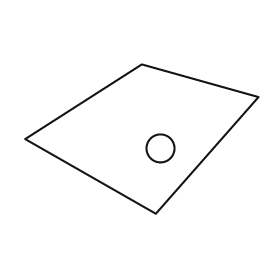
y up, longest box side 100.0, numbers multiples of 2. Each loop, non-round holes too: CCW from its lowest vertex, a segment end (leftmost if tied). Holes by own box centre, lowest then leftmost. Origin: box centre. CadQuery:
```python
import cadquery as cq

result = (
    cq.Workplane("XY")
    .moveTo(6.0, -32.0)
    .lineTo(50.0, 18.0)
    .lineTo(0.0, 32.0)
    .lineTo(-50.0, 0.0)
    .close()
    .moveTo(8.0, -4.0)
    .circle(6.0)
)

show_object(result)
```